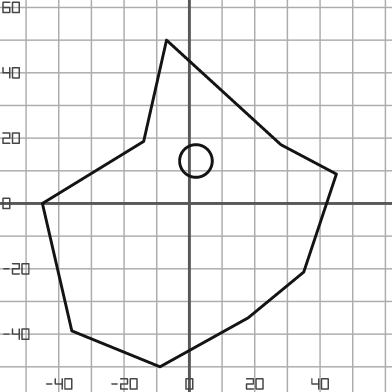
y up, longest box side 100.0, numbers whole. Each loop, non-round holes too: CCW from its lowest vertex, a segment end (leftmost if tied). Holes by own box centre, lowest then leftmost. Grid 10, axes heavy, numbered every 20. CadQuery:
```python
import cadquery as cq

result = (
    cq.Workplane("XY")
    .moveTo(-9.0, -50.0)
    .lineTo(18.0, -35.0)
    .lineTo(35.0, -21.0)
    .lineTo(45.0, 9.0)
    .lineTo(28.0, 18.0)
    .lineTo(-7.0, 50.0)
    .lineTo(-14.0, 19.0)
    .lineTo(-45.0, 0.0)
    .lineTo(-36.0, -39.0)
    .close()
    .moveTo(2.0, 13.0)
    .circle(5.0)
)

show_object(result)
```